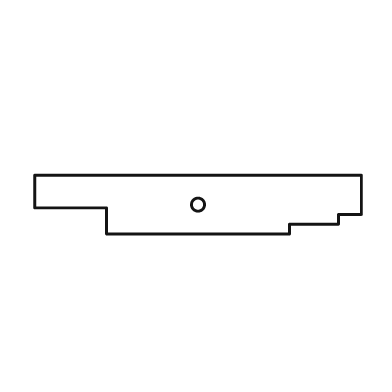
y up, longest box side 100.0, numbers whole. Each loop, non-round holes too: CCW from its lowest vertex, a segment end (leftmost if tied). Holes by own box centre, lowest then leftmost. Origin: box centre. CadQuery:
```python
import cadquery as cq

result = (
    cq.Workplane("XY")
    .moveTo(-28.0, -9.0)
    .lineTo(28.0, -9.0)
    .lineTo(28.0, -6.0)
    .lineTo(43.0, -6.0)
    .lineTo(43.0, -3.0)
    .lineTo(50.0, -3.0)
    .lineTo(50.0, 9.0)
    .lineTo(-50.0, 9.0)
    .lineTo(-50.0, -1.0)
    .lineTo(-28.0, -1.0)
    .close()
    .moveTo(0.0, 0.0)
    .circle(2.0)
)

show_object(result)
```